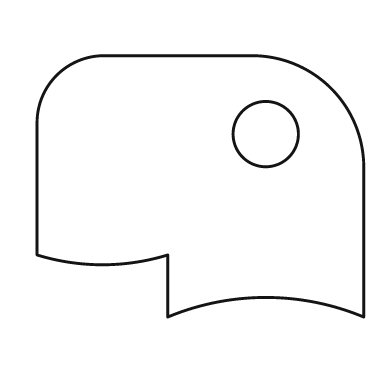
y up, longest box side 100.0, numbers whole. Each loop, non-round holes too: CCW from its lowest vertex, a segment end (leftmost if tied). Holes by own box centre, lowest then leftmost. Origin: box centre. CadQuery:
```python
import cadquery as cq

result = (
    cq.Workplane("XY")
    .moveTo(-10.0, -40.0)
    .threePointArc((20.0, -34.0), (50.0, -40.0))
    .lineTo(50.0, 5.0)
    .threePointArc((40.0, 30.0), (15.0, 40.0))
    .lineTo(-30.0, 40.0)
    .threePointArc((-44.0, 34.0), (-50.0, 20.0))
    .lineTo(-50.0, -21.0)
    .threePointArc((-30.0, -24.0), (-10.0, -21.0))
    .close()
    .moveTo(20.0, 16.0)
    .circle(10.0)
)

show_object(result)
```